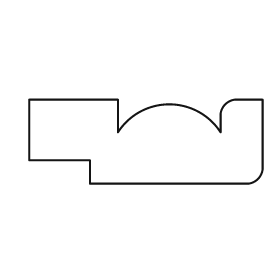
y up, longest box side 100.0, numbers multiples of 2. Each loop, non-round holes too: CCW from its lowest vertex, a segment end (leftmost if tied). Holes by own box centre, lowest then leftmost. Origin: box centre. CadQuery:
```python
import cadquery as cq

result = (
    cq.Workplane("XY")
    .moveTo(-24.0, -18.0)
    .lineTo(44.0, -18.0)
    .threePointArc((48.0, -16.0), (50.0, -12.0))
    .lineTo(50.0, 18.0)
    .lineTo(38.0, 18.0)
    .threePointArc((34.0, 16.0), (32.0, 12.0))
    .lineTo(32.0, 4.0)
    .threePointArc((10.0, 16.0), (-12.0, 4.0))
    .lineTo(-12.0, 18.0)
    .lineTo(-50.0, 18.0)
    .lineTo(-50.0, -8.0)
    .lineTo(-24.0, -8.0)
    .close()
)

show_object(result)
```